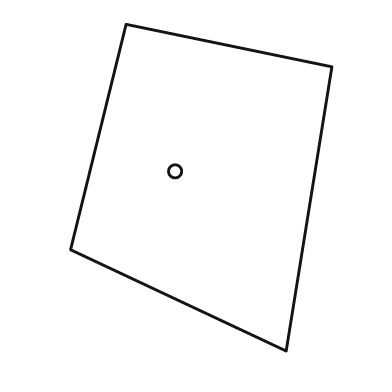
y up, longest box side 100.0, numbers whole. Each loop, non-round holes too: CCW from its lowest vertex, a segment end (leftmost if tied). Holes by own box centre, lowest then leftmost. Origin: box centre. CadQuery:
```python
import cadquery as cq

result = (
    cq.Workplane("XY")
    .moveTo(26.0, -50.0)
    .lineTo(40.0, 37.0)
    .lineTo(-23.0, 50.0)
    .lineTo(-40.0, -19.0)
    .close()
    .moveTo(-8.0, 5.0)
    .circle(2.0)
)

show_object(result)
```